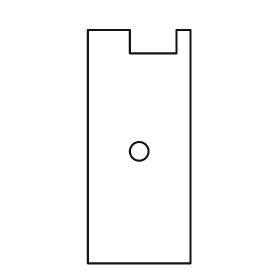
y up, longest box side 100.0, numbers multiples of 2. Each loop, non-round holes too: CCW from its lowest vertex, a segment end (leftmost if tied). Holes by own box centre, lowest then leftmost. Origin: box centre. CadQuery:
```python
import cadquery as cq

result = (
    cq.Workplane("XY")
    .moveTo(-22.0, -50.0)
    .lineTo(22.0, -50.0)
    .lineTo(22.0, 50.0)
    .lineTo(16.0, 50.0)
    .lineTo(16.0, 40.0)
    .lineTo(-4.0, 40.0)
    .lineTo(-4.0, 50.0)
    .lineTo(-22.0, 50.0)
    .close()
    .moveTo(0.0, -2.0)
    .circle(4.0)
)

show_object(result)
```